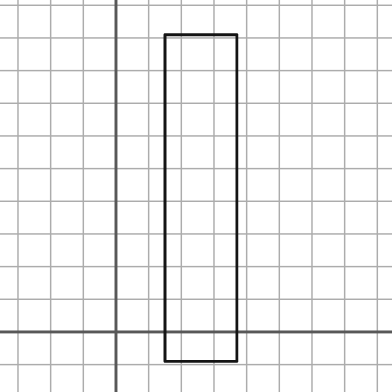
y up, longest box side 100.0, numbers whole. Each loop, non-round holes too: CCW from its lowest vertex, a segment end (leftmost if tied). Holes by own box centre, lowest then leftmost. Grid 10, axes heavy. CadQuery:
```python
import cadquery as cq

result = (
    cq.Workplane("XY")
    .moveTo(15.0, -9.0)
    .lineTo(37.0, -9.0)
    .lineTo(37.0, 91.0)
    .lineTo(15.0, 91.0)
    .close()
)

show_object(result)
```